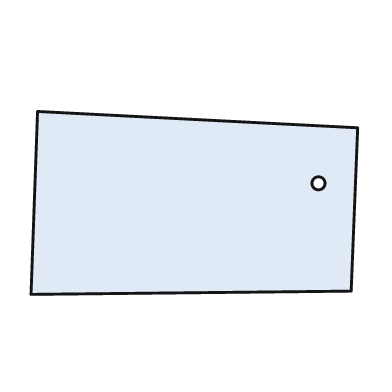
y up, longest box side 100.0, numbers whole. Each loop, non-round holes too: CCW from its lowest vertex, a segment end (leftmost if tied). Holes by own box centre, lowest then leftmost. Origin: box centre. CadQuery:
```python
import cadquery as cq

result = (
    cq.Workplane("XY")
    .moveTo(-50.0, -28.0)
    .lineTo(48.0, -27.0)
    .lineTo(50.0, 23.0)
    .lineTo(-48.0, 28.0)
    .close()
    .moveTo(38.0, 6.0)
    .circle(2.0)
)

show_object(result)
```